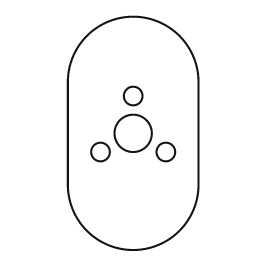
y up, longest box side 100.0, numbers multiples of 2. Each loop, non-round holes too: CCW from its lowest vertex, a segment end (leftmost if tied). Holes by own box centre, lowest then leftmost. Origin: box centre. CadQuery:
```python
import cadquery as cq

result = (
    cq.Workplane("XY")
    .moveTo(-28.0, -22.0)
    .threePointArc((0.0, -50.0), (28.0, -22.0))
    .lineTo(28.0, 22.0)
    .threePointArc((0.0, 50.0), (-28.0, 22.0))
    .close()
    .moveTo(-14.0, -8.0)
    .circle(4.0)
    .moveTo(14.0, -8.0)
    .circle(4.0)
    .moveTo(0.0, 0.0)
    .circle(8.0)
    .moveTo(0.0, 16.0)
    .circle(4.0)
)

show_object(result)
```